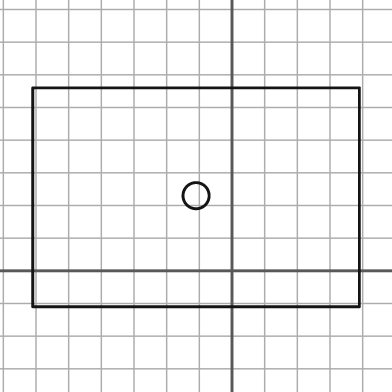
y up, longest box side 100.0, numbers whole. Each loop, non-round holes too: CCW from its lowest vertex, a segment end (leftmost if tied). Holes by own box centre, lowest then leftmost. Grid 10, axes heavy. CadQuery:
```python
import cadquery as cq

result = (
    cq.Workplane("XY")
    .moveTo(-61.0, -11.0)
    .lineTo(39.0, -11.0)
    .lineTo(39.0, 56.0)
    .lineTo(-61.0, 56.0)
    .close()
    .moveTo(-11.0, 23.0)
    .circle(4.0)
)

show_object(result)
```